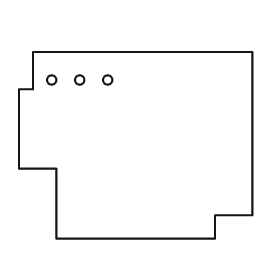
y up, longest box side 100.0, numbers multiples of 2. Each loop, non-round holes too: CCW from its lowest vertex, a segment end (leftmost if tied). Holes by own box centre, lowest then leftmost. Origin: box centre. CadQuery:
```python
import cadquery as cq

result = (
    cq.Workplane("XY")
    .moveTo(-34.0, -40.0)
    .lineTo(34.0, -40.0)
    .lineTo(34.0, -30.0)
    .lineTo(50.0, -30.0)
    .lineTo(50.0, 40.0)
    .lineTo(-44.0, 40.0)
    .lineTo(-44.0, 24.0)
    .lineTo(-50.0, 24.0)
    .lineTo(-50.0, -10.0)
    .lineTo(-34.0, -10.0)
    .close()
    .moveTo(-36.0, 28.0)
    .circle(2.0)
    .moveTo(-24.0, 28.0)
    .circle(2.0)
    .moveTo(-12.0, 28.0)
    .circle(2.0)
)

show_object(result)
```